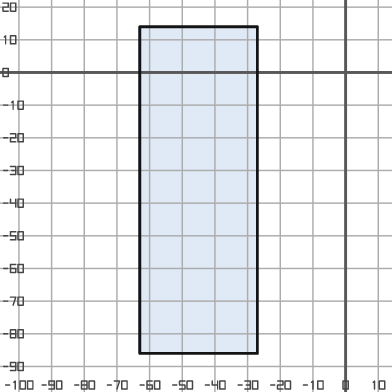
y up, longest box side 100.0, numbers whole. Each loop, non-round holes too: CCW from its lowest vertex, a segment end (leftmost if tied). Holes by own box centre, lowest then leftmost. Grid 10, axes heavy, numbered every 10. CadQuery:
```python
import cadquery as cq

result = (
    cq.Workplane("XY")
    .moveTo(-63.0, -86.0)
    .lineTo(-27.0, -86.0)
    .lineTo(-27.0, 14.0)
    .lineTo(-63.0, 14.0)
    .close()
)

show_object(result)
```